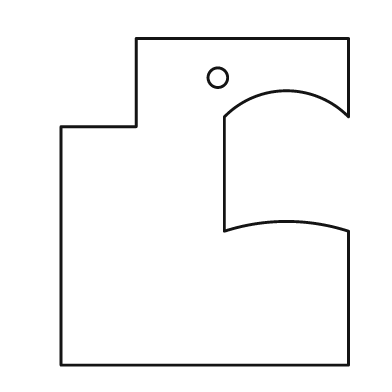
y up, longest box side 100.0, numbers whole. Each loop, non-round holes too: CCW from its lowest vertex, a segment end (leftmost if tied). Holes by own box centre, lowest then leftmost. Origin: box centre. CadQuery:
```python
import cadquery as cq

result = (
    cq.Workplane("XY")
    .moveTo(-44.0, -50.0)
    .lineTo(44.0, -50.0)
    .lineTo(44.0, -9.0)
    .threePointArc((25.0, -6.0), (6.0, -9.0))
    .lineTo(6.0, 26.0)
    .threePointArc((25.0, 34.0), (44.0, 26.0))
    .lineTo(44.0, 50.0)
    .lineTo(-21.0, 50.0)
    .lineTo(-21.0, 23.0)
    .lineTo(-44.0, 23.0)
    .close()
    .moveTo(4.0, 38.0)
    .circle(3.0)
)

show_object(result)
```